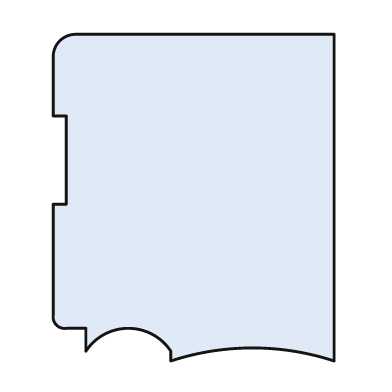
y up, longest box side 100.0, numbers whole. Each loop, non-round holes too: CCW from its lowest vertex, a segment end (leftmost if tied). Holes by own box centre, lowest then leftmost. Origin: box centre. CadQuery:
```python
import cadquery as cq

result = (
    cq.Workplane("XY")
    .moveTo(-7.0, -50.0)
    .threePointArc((18.0, -46.0), (43.0, -50.0))
    .lineTo(43.0, 50.0)
    .lineTo(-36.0, 50.0)
    .threePointArc((-41.0, 48.0), (-43.0, 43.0))
    .lineTo(-43.0, 25.0)
    .lineTo(-39.0, 25.0)
    .lineTo(-39.0, -2.0)
    .lineTo(-43.0, -2.0)
    .lineTo(-43.0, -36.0)
    .threePointArc((-42.0, -39.0), (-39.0, -40.0))
    .lineTo(-33.0, -40.0)
    .lineTo(-33.0, -47.0)
    .threePointArc((-20.0, -40.0), (-7.0, -47.0))
    .close()
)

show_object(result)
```